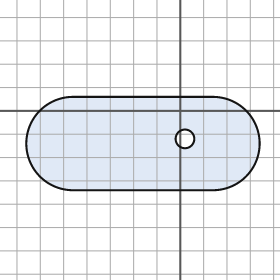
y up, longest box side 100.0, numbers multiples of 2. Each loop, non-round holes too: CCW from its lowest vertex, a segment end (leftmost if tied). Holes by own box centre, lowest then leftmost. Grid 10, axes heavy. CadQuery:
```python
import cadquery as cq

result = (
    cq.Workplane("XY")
    .moveTo(-46.0, -34.0)
    .lineTo(14.0, -34.0)
    .threePointArc((34.0, -14.0), (14.0, 6.0))
    .lineTo(-46.0, 6.0)
    .threePointArc((-66.0, -14.0), (-46.0, -34.0))
    .close()
    .moveTo(2.0, -12.0)
    .circle(4.0)
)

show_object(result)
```